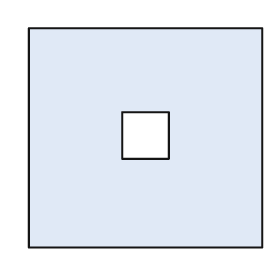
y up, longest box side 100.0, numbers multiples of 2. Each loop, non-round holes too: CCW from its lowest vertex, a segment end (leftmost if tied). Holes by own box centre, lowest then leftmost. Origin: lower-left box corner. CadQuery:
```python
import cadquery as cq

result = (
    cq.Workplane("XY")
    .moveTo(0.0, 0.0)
    .lineTo(100.0, 0.0)
    .lineTo(100.0, 94.0)
    .lineTo(0.0, 94.0)
    .close()
    .moveTo(40.0, 38.0)
    .lineTo(60.0, 38.0)
    .lineTo(60.0, 58.0)
    .lineTo(40.0, 58.0)
    .close()
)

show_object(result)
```